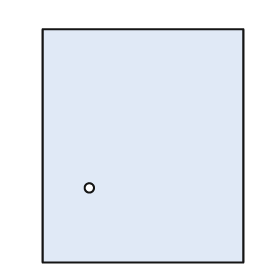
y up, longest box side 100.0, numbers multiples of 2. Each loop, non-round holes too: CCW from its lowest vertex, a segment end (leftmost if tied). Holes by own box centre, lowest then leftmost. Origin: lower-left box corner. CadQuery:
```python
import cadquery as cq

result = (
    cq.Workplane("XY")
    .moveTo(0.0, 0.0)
    .lineTo(86.0, 0.0)
    .lineTo(86.0, 100.0)
    .lineTo(0.0, 100.0)
    .close()
    .moveTo(20.0, 32.0)
    .circle(2.0)
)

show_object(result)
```